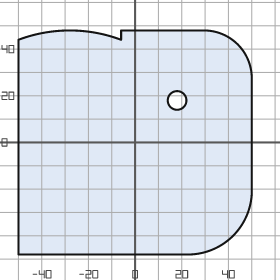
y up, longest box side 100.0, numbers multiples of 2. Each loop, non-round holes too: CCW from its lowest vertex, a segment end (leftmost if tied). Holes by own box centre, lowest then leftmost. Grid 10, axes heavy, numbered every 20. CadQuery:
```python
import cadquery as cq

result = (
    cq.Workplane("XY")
    .moveTo(-50.0, -48.0)
    .lineTo(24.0, -48.0)
    .threePointArc((42.0, -40.0), (50.0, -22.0))
    .lineTo(50.0, 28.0)
    .threePointArc((44.0, 42.0), (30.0, 48.0))
    .lineTo(-6.0, 48.0)
    .lineTo(-6.0, 44.0)
    .threePointArc((-28.0, 48.0), (-50.0, 44.0))
    .close()
    .moveTo(18.0, 18.0)
    .circle(4.0)
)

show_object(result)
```